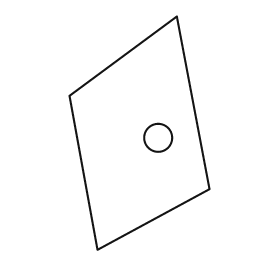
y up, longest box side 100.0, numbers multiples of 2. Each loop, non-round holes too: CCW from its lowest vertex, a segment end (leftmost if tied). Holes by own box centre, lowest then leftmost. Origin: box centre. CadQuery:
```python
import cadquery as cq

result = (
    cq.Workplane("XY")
    .moveTo(-18.0, -50.0)
    .lineTo(30.0, -24.0)
    .lineTo(16.0, 50.0)
    .lineTo(-30.0, 16.0)
    .close()
    .moveTo(8.0, -2.0)
    .circle(6.0)
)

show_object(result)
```